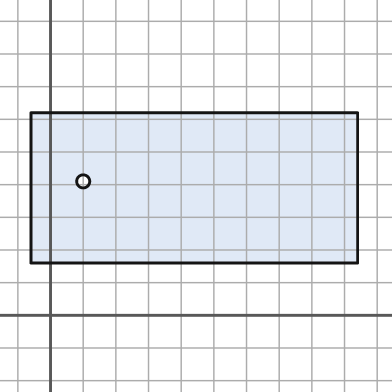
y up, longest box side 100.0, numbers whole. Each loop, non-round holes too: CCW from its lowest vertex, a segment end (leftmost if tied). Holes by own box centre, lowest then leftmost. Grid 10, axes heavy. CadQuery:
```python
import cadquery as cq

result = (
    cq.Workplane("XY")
    .moveTo(-6.0, 16.0)
    .lineTo(94.0, 16.0)
    .lineTo(94.0, 62.0)
    .lineTo(-6.0, 62.0)
    .close()
    .moveTo(10.0, 41.0)
    .circle(2.0)
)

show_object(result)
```